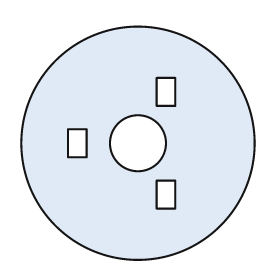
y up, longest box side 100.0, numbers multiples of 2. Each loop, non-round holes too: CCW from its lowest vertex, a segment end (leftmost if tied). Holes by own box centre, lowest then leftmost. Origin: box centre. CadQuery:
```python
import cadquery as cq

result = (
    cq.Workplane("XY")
    .moveTo(0.0, 0.0)
    .circle(50.0)
    .moveTo(8.0, -28.0)
    .lineTo(16.0, -28.0)
    .lineTo(16.0, -16.0)
    .lineTo(8.0, -16.0)
    .close()
    .moveTo(-30.0, -6.0)
    .lineTo(-22.0, -6.0)
    .lineTo(-22.0, 6.0)
    .lineTo(-30.0, 6.0)
    .close()
    .moveTo(0.0, 0.0)
    .circle(12.0)
    .moveTo(8.0, 16.0)
    .lineTo(16.0, 16.0)
    .lineTo(16.0, 28.0)
    .lineTo(8.0, 28.0)
    .close()
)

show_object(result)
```